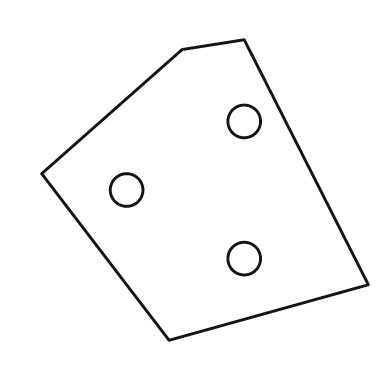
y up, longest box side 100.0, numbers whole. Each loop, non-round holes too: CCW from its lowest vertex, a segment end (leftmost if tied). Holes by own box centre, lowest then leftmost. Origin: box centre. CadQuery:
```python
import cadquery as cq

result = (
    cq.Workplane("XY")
    .moveTo(-11.0, -46.0)
    .lineTo(50.0, -29.0)
    .lineTo(12.0, 46.0)
    .lineTo(-7.0, 43.0)
    .lineTo(-50.0, 5.0)
    .close()
    .moveTo(12.0, -21.0)
    .circle(5.0)
    .moveTo(-24.0, 0.0)
    .circle(5.0)
    .moveTo(12.0, 21.0)
    .circle(5.0)
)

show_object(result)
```